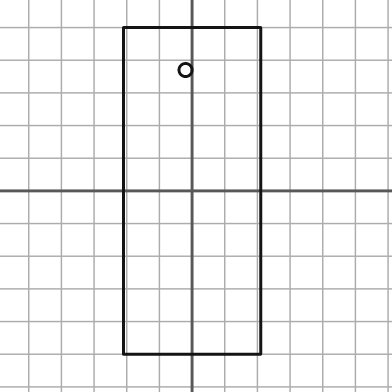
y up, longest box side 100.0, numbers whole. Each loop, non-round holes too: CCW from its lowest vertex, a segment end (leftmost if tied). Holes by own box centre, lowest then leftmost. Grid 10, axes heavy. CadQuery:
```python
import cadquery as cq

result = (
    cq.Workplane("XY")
    .moveTo(-21.0, -50.0)
    .lineTo(21.0, -50.0)
    .lineTo(21.0, 50.0)
    .lineTo(-21.0, 50.0)
    .close()
    .moveTo(-2.0, 37.0)
    .circle(2.0)
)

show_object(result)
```